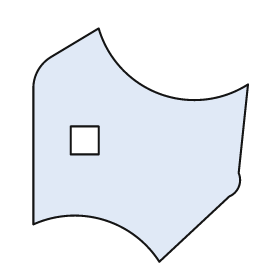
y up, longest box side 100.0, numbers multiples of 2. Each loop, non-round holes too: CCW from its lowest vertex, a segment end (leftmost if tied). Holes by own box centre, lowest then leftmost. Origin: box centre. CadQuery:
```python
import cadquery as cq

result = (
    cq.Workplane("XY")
    .moveTo(8.0, -50.0)
    .lineTo(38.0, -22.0)
    .threePointArc((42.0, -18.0), (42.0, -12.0))
    .lineTo(46.0, 26.0)
    .threePointArc((8.0, 22.0), (-18.0, 50.0))
    .lineTo(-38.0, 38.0)
    .threePointArc((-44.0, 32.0), (-46.0, 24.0))
    .lineTo(-46.0, -34.0)
    .threePointArc((-16.0, -32.0), (8.0, -50.0))
    .close()
    .moveTo(-30.0, -4.0)
    .lineTo(-18.0, -4.0)
    .lineTo(-18.0, 8.0)
    .lineTo(-30.0, 8.0)
    .close()
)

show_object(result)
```